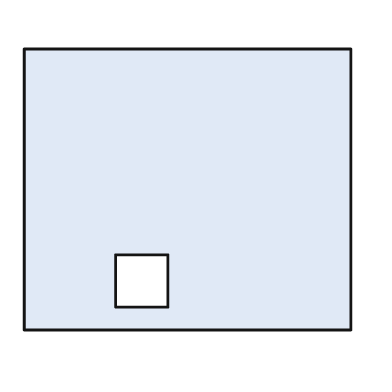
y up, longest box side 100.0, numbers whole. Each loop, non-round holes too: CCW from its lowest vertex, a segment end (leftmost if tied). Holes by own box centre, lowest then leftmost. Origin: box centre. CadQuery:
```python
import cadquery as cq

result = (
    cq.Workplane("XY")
    .moveTo(-50.0, -43.0)
    .lineTo(50.0, -43.0)
    .lineTo(50.0, 43.0)
    .lineTo(-50.0, 43.0)
    .close()
    .moveTo(-22.0, -36.0)
    .lineTo(-6.0, -36.0)
    .lineTo(-6.0, -20.0)
    .lineTo(-22.0, -20.0)
    .close()
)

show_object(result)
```